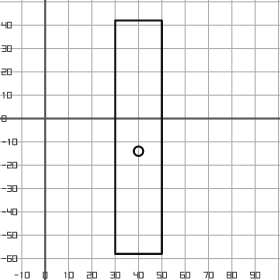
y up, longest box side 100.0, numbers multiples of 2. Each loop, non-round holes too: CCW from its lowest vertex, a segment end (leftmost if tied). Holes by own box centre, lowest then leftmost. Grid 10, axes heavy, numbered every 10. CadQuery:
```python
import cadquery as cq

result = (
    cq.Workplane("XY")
    .moveTo(30.0, -58.0)
    .lineTo(50.0, -58.0)
    .lineTo(50.0, 42.0)
    .lineTo(30.0, 42.0)
    .close()
    .moveTo(40.0, -14.0)
    .circle(2.0)
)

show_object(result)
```